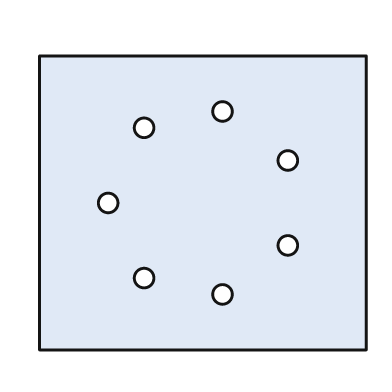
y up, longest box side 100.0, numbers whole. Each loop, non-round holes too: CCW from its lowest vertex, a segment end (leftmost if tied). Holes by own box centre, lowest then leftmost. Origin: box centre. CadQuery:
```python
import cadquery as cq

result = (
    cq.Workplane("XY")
    .moveTo(-50.0, -45.0)
    .lineTo(50.0, -45.0)
    .lineTo(50.0, 45.0)
    .lineTo(-50.0, 45.0)
    .close()
    .moveTo(6.0, -28.0)
    .circle(3.0)
    .moveTo(-18.0, -23.0)
    .circle(3.0)
    .moveTo(26.0, -13.0)
    .circle(3.0)
    .moveTo(-29.0, 0.0)
    .circle(3.0)
    .moveTo(26.0, 13.0)
    .circle(3.0)
    .moveTo(-18.0, 23.0)
    .circle(3.0)
    .moveTo(6.0, 28.0)
    .circle(3.0)
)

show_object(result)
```